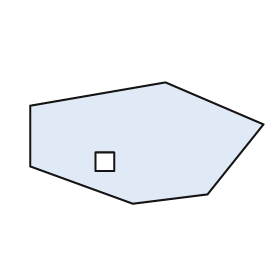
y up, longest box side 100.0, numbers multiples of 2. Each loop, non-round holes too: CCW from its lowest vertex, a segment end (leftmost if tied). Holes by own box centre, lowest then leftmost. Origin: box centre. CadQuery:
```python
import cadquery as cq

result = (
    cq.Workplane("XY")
    .moveTo(-6.0, -26.0)
    .lineTo(26.0, -22.0)
    .lineTo(50.0, 8.0)
    .lineTo(8.0, 26.0)
    .lineTo(-50.0, 16.0)
    .lineTo(-50.0, -10.0)
    .close()
    .moveTo(-22.0, -12.0)
    .lineTo(-14.0, -12.0)
    .lineTo(-14.0, -4.0)
    .lineTo(-22.0, -4.0)
    .close()
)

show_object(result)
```